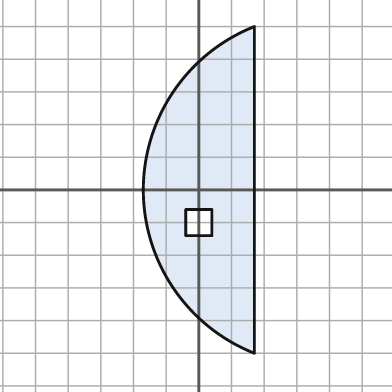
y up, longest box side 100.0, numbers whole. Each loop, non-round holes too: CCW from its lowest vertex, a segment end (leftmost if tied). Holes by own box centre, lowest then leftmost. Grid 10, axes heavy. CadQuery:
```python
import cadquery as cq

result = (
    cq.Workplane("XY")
    .moveTo(17.0, -50.0)
    .lineTo(17.0, 50.0)
    .threePointArc((-17.0, 0.0), (17.0, -50.0))
    .close()
    .moveTo(-4.0, -14.0)
    .lineTo(4.0, -14.0)
    .lineTo(4.0, -6.0)
    .lineTo(-4.0, -6.0)
    .close()
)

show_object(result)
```